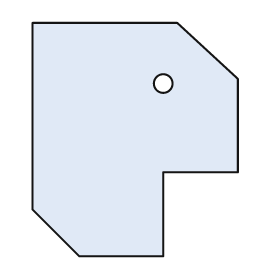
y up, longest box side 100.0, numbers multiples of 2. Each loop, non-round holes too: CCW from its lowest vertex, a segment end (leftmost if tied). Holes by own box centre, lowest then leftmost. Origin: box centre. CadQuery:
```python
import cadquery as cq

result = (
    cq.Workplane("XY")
    .moveTo(-24.0, -50.0)
    .lineTo(12.0, -50.0)
    .lineTo(12.0, -14.0)
    .lineTo(44.0, -14.0)
    .lineTo(44.0, 26.0)
    .lineTo(18.0, 50.0)
    .lineTo(-44.0, 50.0)
    .lineTo(-44.0, -30.0)
    .close()
    .moveTo(12.0, 24.0)
    .circle(4.0)
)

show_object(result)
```